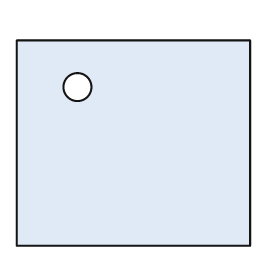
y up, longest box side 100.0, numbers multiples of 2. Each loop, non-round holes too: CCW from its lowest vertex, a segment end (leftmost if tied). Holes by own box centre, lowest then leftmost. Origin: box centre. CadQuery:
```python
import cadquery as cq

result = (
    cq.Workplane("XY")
    .moveTo(-50.0, -44.0)
    .lineTo(50.0, -44.0)
    .lineTo(50.0, 44.0)
    .lineTo(-50.0, 44.0)
    .close()
    .moveTo(-24.0, 24.0)
    .circle(6.0)
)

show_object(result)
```